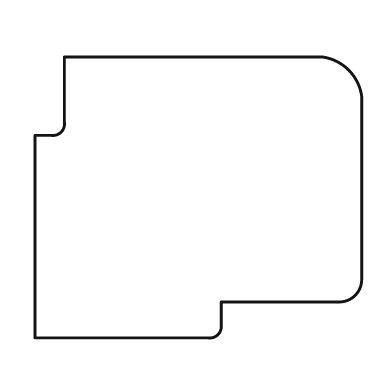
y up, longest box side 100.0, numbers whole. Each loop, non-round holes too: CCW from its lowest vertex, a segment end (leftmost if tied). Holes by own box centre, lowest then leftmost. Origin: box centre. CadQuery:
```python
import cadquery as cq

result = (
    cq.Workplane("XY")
    .moveTo(-50.0, -43.0)
    .lineTo(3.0, -43.0)
    .threePointArc((6.0, -42.0), (7.0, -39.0))
    .lineTo(7.0, -32.0)
    .lineTo(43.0, -32.0)
    .threePointArc((48.0, -30.0), (50.0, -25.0))
    .lineTo(50.0, 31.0)
    .threePointArc((46.0, 39.0), (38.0, 43.0))
    .lineTo(-41.0, 43.0)
    .lineTo(-41.0, 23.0)
    .threePointArc((-42.0, 20.0), (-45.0, 19.0))
    .lineTo(-50.0, 19.0)
    .close()
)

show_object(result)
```